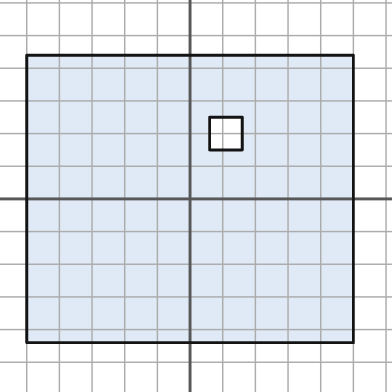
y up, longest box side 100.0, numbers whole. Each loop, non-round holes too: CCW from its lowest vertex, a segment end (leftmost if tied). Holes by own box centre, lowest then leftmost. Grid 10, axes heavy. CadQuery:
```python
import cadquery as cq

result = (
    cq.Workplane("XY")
    .moveTo(-50.0, -44.0)
    .lineTo(50.0, -44.0)
    .lineTo(50.0, 44.0)
    .lineTo(-50.0, 44.0)
    .close()
    .moveTo(6.0, 15.0)
    .lineTo(16.0, 15.0)
    .lineTo(16.0, 25.0)
    .lineTo(6.0, 25.0)
    .close()
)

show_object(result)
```